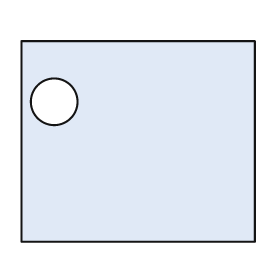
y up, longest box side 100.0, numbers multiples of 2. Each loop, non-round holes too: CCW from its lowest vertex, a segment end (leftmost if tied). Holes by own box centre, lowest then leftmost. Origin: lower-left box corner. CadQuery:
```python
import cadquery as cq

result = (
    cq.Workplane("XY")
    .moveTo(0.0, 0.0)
    .lineTo(100.0, 0.0)
    .lineTo(100.0, 86.0)
    .lineTo(0.0, 86.0)
    .close()
    .moveTo(14.0, 60.0)
    .circle(10.0)
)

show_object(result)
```